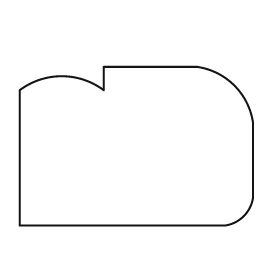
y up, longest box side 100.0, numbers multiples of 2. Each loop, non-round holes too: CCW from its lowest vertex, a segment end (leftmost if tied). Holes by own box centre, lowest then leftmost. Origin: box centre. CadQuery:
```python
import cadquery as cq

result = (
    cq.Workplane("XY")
    .moveTo(-50.0, -34.0)
    .lineTo(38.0, -34.0)
    .threePointArc((46.0, -30.0), (50.0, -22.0))
    .lineTo(50.0, 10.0)
    .threePointArc((42.0, 26.0), (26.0, 34.0))
    .lineTo(-14.0, 34.0)
    .lineTo(-14.0, 24.0)
    .threePointArc((-32.0, 30.0), (-50.0, 24.0))
    .close()
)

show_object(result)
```